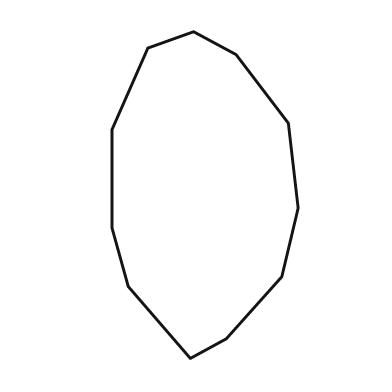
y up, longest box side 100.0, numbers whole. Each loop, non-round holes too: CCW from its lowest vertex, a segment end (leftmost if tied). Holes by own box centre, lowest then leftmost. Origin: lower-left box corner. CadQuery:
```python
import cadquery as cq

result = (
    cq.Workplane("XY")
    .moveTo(24.0, 0.0)
    .lineTo(35.0, 6.0)
    .lineTo(52.0, 25.0)
    .lineTo(57.0, 46.0)
    .lineTo(54.0, 72.0)
    .lineTo(38.0, 93.0)
    .lineTo(25.0, 100.0)
    .lineTo(11.0, 95.0)
    .lineTo(0.0, 70.0)
    .lineTo(0.0, 40.0)
    .lineTo(5.0, 22.0)
    .close()
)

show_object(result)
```